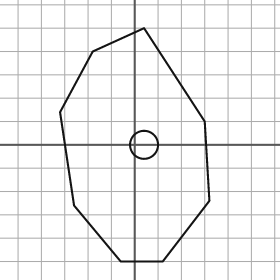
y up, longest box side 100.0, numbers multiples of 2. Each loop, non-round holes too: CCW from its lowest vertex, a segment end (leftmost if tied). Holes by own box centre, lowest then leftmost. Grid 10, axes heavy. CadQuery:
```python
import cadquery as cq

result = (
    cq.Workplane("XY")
    .moveTo(-6.0, -50.0)
    .lineTo(12.0, -50.0)
    .lineTo(32.0, -24.0)
    .lineTo(30.0, 10.0)
    .lineTo(4.0, 50.0)
    .lineTo(-18.0, 40.0)
    .lineTo(-32.0, 14.0)
    .lineTo(-26.0, -26.0)
    .close()
    .moveTo(4.0, 0.0)
    .circle(6.0)
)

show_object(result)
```